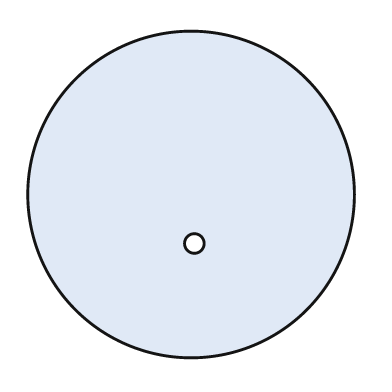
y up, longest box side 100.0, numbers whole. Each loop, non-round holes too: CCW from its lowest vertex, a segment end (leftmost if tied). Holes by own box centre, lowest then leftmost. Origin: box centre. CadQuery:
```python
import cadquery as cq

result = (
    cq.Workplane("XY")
    .moveTo(0.0, 0.0)
    .circle(50.0)
    .moveTo(1.0, -15.0)
    .circle(3.0)
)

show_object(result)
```